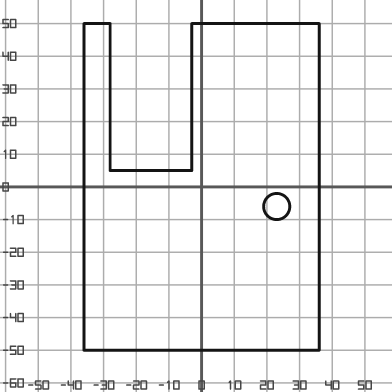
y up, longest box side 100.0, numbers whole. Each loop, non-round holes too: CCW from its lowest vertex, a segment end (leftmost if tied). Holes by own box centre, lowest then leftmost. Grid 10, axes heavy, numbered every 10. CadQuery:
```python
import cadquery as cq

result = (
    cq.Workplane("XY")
    .moveTo(-36.0, -50.0)
    .lineTo(36.0, -50.0)
    .lineTo(36.0, 50.0)
    .lineTo(-3.0, 50.0)
    .lineTo(-3.0, 5.0)
    .lineTo(-28.0, 5.0)
    .lineTo(-28.0, 50.0)
    .lineTo(-36.0, 50.0)
    .close()
    .moveTo(23.0, -6.0)
    .circle(4.0)
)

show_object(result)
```